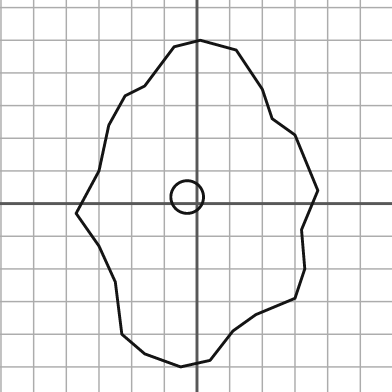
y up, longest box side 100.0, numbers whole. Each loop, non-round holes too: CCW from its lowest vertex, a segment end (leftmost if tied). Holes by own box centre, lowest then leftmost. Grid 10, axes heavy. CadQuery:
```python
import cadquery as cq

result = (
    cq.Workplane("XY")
    .moveTo(-5.0, -50.0)
    .lineTo(4.0, -48.0)
    .lineTo(11.0, -39.0)
    .lineTo(18.0, -34.0)
    .lineTo(30.0, -29.0)
    .lineTo(33.0, -20.0)
    .lineTo(32.0, -8.0)
    .lineTo(37.0, 4.0)
    .lineTo(30.0, 21.0)
    .lineTo(23.0, 26.0)
    .lineTo(20.0, 35.0)
    .lineTo(12.0, 47.0)
    .lineTo(1.0, 50.0)
    .lineTo(-7.0, 48.0)
    .lineTo(-16.0, 36.0)
    .lineTo(-22.0, 33.0)
    .lineTo(-27.0, 24.0)
    .lineTo(-30.0, 10.0)
    .lineTo(-37.0, -3.0)
    .lineTo(-30.0, -13.0)
    .lineTo(-25.0, -24.0)
    .lineTo(-23.0, -40.0)
    .lineTo(-16.0, -46.0)
    .close()
    .moveTo(-3.0, 2.0)
    .circle(5.0)
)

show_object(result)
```